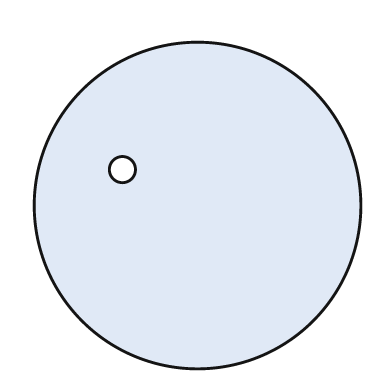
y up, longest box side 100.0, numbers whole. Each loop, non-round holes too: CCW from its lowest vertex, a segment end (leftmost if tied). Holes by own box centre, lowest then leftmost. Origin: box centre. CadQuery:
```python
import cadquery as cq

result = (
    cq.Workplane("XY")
    .moveTo(0.0, 0.0)
    .circle(50.0)
    .moveTo(-23.0, 11.0)
    .circle(4.0)
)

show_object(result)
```